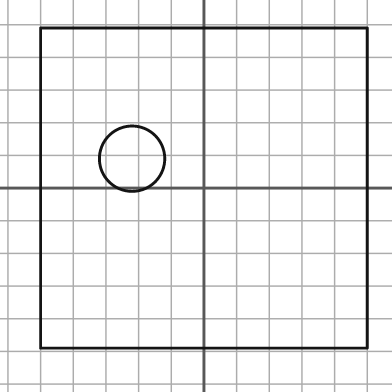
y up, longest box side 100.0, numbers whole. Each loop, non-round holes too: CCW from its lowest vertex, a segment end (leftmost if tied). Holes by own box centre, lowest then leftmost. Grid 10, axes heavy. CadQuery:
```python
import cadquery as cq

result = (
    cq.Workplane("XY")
    .moveTo(-50.0, -49.0)
    .lineTo(50.0, -49.0)
    .lineTo(50.0, 49.0)
    .lineTo(-50.0, 49.0)
    .close()
    .moveTo(-22.0, 9.0)
    .circle(10.0)
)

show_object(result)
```